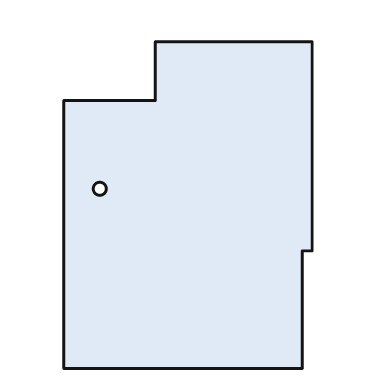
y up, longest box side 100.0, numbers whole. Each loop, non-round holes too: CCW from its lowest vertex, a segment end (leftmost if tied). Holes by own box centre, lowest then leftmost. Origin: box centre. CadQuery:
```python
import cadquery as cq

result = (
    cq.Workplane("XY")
    .moveTo(-38.0, -50.0)
    .lineTo(35.0, -50.0)
    .lineTo(35.0, -14.0)
    .lineTo(38.0, -14.0)
    .lineTo(38.0, 50.0)
    .lineTo(-10.0, 50.0)
    .lineTo(-10.0, 32.0)
    .lineTo(-38.0, 32.0)
    .close()
    .moveTo(-27.0, 5.0)
    .circle(2.0)
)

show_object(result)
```